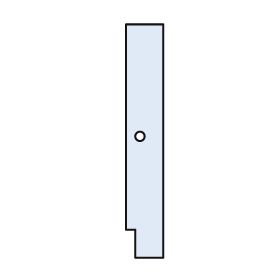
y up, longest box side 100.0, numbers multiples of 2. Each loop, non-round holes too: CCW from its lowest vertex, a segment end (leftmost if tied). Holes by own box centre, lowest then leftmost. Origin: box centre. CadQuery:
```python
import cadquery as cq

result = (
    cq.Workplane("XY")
    .moveTo(-4.0, -50.0)
    .lineTo(8.0, -50.0)
    .lineTo(8.0, 50.0)
    .lineTo(-8.0, 50.0)
    .lineTo(-8.0, -38.0)
    .lineTo(-4.0, -38.0)
    .close()
    .moveTo(-2.0, 2.0)
    .circle(2.0)
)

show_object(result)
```